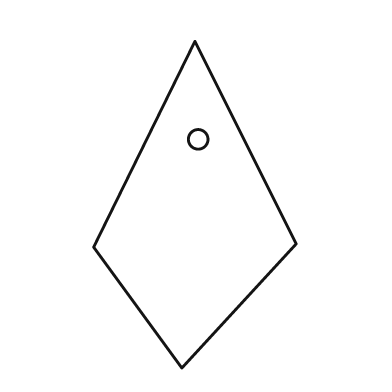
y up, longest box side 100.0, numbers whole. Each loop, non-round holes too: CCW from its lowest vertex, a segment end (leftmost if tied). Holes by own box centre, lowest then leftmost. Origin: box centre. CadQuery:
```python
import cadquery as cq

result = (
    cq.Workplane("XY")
    .moveTo(-4.0, -50.0)
    .lineTo(31.0, -12.0)
    .lineTo(0.0, 50.0)
    .lineTo(-31.0, -13.0)
    .close()
    .moveTo(1.0, 20.0)
    .circle(3.0)
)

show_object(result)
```